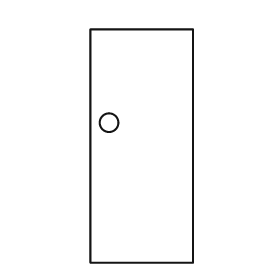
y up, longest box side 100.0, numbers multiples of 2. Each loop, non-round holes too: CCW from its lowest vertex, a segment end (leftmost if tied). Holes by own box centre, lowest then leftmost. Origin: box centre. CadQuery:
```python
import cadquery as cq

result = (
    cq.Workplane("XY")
    .moveTo(-22.0, -50.0)
    .lineTo(22.0, -50.0)
    .lineTo(22.0, 50.0)
    .lineTo(-22.0, 50.0)
    .close()
    .moveTo(-14.0, 10.0)
    .circle(4.0)
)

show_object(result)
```